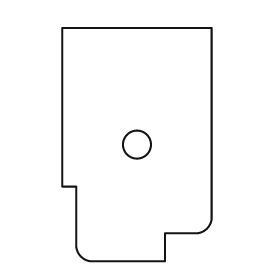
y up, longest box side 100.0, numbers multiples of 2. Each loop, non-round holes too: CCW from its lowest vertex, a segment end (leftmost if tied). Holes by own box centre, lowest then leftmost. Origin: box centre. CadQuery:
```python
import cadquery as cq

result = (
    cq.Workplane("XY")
    .moveTo(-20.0, -50.0)
    .lineTo(12.0, -50.0)
    .lineTo(12.0, -38.0)
    .lineTo(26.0, -38.0)
    .threePointArc((30.0, -36.0), (32.0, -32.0))
    .lineTo(32.0, 50.0)
    .lineTo(-32.0, 50.0)
    .lineTo(-32.0, -18.0)
    .lineTo(-26.0, -18.0)
    .lineTo(-26.0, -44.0)
    .threePointArc((-24.0, -48.0), (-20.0, -50.0))
    .close()
    .moveTo(0.0, 0.0)
    .circle(6.0)
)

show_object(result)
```